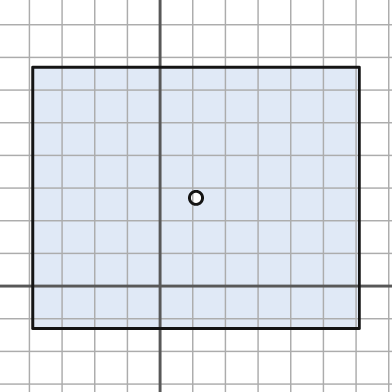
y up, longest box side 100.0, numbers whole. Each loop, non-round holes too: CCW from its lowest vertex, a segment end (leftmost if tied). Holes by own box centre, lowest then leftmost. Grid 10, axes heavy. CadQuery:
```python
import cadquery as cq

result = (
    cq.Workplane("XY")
    .moveTo(-39.0, -13.0)
    .lineTo(61.0, -13.0)
    .lineTo(61.0, 67.0)
    .lineTo(-39.0, 67.0)
    .close()
    .moveTo(11.0, 27.0)
    .circle(2.0)
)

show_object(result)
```